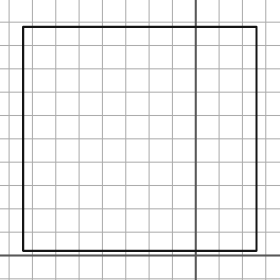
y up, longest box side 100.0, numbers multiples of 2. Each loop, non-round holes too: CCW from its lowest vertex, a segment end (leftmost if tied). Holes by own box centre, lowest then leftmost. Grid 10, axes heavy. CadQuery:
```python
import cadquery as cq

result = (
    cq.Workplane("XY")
    .moveTo(-74.0, 2.0)
    .lineTo(26.0, 2.0)
    .lineTo(26.0, 98.0)
    .lineTo(-74.0, 98.0)
    .close()
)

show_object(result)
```